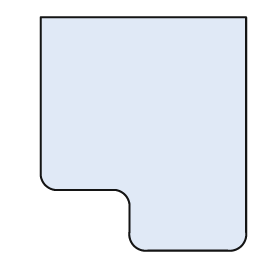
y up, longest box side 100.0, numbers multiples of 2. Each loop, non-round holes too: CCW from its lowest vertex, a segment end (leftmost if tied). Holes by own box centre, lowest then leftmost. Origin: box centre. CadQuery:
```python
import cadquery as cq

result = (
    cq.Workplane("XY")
    .moveTo(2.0, -50.0)
    .lineTo(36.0, -50.0)
    .threePointArc((42.0, -48.0), (44.0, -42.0))
    .lineTo(44.0, 50.0)
    .lineTo(-44.0, 50.0)
    .lineTo(-44.0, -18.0)
    .threePointArc((-42.0, -22.0), (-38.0, -24.0))
    .lineTo(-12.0, -24.0)
    .threePointArc((-8.0, -26.0), (-6.0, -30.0))
    .lineTo(-6.0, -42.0)
    .threePointArc((-4.0, -48.0), (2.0, -50.0))
    .close()
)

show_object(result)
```